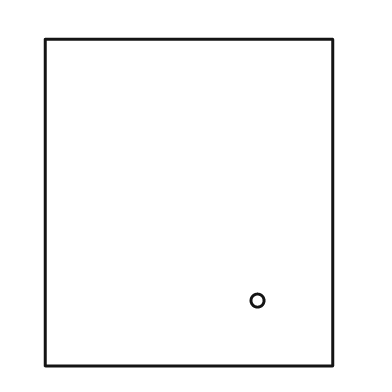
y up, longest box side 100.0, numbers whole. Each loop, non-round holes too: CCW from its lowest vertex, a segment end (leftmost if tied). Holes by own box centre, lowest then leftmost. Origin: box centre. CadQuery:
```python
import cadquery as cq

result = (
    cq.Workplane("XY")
    .moveTo(-44.0, -50.0)
    .lineTo(44.0, -50.0)
    .lineTo(44.0, 50.0)
    .lineTo(-44.0, 50.0)
    .close()
    .moveTo(21.0, -30.0)
    .circle(2.0)
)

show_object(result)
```